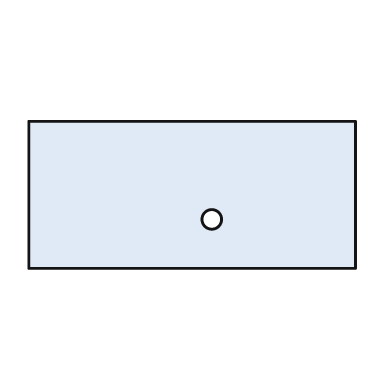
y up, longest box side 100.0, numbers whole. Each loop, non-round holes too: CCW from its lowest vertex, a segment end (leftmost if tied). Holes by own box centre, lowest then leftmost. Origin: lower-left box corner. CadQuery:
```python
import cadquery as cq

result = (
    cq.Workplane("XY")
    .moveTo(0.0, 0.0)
    .lineTo(100.0, 0.0)
    .lineTo(100.0, 45.0)
    .lineTo(0.0, 45.0)
    .close()
    .moveTo(56.0, 15.0)
    .circle(3.0)
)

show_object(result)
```